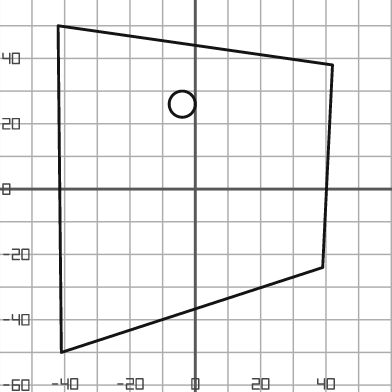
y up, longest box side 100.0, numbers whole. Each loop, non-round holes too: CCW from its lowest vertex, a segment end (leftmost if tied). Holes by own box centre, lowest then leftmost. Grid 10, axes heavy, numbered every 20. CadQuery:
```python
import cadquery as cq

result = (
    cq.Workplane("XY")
    .moveTo(-41.0, -50.0)
    .lineTo(39.0, -24.0)
    .lineTo(42.0, 38.0)
    .lineTo(-42.0, 50.0)
    .close()
    .moveTo(-4.0, 26.0)
    .circle(4.0)
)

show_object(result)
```